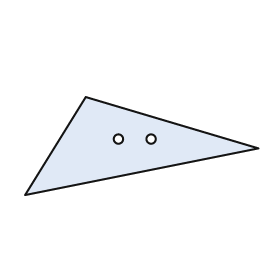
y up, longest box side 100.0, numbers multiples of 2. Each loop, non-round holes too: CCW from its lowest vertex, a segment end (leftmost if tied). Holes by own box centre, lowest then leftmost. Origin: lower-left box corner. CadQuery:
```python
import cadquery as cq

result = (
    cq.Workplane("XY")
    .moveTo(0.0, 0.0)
    .lineTo(100.0, 20.0)
    .lineTo(26.0, 42.0)
    .close()
    .moveTo(40.0, 24.0)
    .circle(2.0)
    .moveTo(54.0, 24.0)
    .circle(2.0)
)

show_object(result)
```